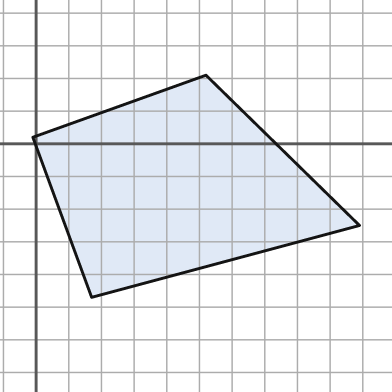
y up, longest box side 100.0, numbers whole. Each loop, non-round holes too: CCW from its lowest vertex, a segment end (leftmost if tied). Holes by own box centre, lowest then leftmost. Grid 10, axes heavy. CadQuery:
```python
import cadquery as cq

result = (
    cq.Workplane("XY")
    .moveTo(17.0, -47.0)
    .lineTo(99.0, -25.0)
    .lineTo(52.0, 21.0)
    .lineTo(-1.0, 2.0)
    .close()
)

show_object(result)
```